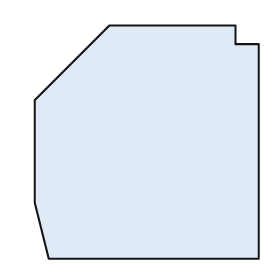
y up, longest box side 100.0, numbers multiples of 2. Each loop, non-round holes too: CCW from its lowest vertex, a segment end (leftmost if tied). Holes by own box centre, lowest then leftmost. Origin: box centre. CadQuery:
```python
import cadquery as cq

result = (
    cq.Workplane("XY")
    .moveTo(-42.0, -50.0)
    .lineTo(48.0, -50.0)
    .lineTo(48.0, 42.0)
    .lineTo(38.0, 42.0)
    .lineTo(38.0, 50.0)
    .lineTo(-16.0, 50.0)
    .lineTo(-48.0, 18.0)
    .lineTo(-48.0, -26.0)
    .close()
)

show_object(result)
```